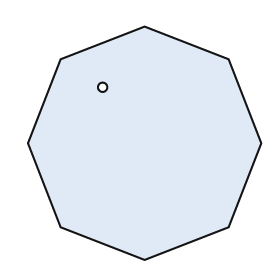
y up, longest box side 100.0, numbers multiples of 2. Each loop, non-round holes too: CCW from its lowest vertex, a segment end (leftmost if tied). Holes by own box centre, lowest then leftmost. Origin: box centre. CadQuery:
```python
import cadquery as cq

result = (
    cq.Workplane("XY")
    .moveTo(0.0, -50.0)
    .lineTo(36.0, -36.0)
    .lineTo(50.0, 0.0)
    .lineTo(36.0, 36.0)
    .lineTo(0.0, 50.0)
    .lineTo(-36.0, 36.0)
    .lineTo(-50.0, 0.0)
    .lineTo(-36.0, -36.0)
    .close()
    .moveTo(-18.0, 24.0)
    .circle(2.0)
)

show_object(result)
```